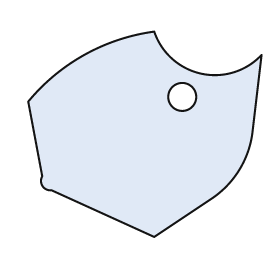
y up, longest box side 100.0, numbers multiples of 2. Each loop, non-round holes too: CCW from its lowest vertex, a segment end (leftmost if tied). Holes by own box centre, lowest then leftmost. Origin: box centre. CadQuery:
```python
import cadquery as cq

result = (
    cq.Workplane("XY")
    .moveTo(4.0, -44.0)
    .lineTo(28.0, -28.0)
    .threePointArc((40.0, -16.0), (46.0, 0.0))
    .lineTo(50.0, 34.0)
    .threePointArc((24.0, 26.0), (4.0, 44.0))
    .threePointArc((-26.0, 34.0), (-50.0, 14.0))
    .lineTo(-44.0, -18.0)
    .threePointArc((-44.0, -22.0), (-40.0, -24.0))
    .close()
    .moveTo(16.0, 16.0)
    .circle(6.0)
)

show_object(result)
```